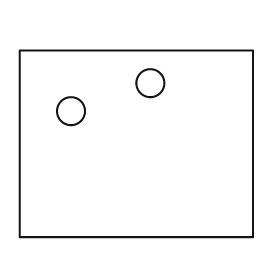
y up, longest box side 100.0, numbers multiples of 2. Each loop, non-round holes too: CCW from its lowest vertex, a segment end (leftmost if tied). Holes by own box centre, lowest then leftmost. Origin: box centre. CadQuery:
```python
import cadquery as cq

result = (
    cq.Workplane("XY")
    .moveTo(-50.0, -40.0)
    .lineTo(50.0, -40.0)
    .lineTo(50.0, 40.0)
    .lineTo(-50.0, 40.0)
    .close()
    .moveTo(-28.0, 14.0)
    .circle(6.0)
    .moveTo(6.0, 26.0)
    .circle(6.0)
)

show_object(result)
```